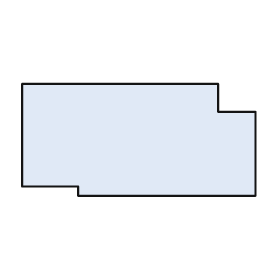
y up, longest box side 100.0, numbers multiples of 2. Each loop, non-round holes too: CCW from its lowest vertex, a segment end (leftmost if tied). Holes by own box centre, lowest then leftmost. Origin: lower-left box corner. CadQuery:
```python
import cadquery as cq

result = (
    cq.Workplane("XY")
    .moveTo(24.0, 0.0)
    .lineTo(100.0, 0.0)
    .lineTo(100.0, 36.0)
    .lineTo(84.0, 36.0)
    .lineTo(84.0, 48.0)
    .lineTo(0.0, 48.0)
    .lineTo(0.0, 4.0)
    .lineTo(24.0, 4.0)
    .close()
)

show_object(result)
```